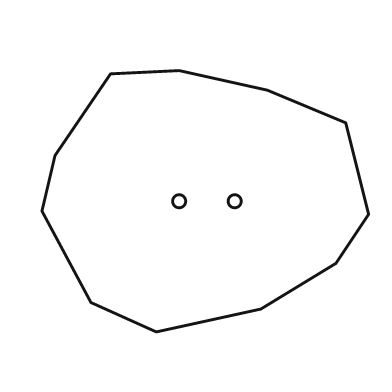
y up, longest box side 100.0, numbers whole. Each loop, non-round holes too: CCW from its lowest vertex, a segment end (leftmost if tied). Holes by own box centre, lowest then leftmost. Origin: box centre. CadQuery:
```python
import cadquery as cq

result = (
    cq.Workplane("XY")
    .moveTo(-15.0, -40.0)
    .lineTo(17.0, -33.0)
    .lineTo(40.0, -19.0)
    .lineTo(50.0, -4.0)
    .lineTo(43.0, 24.0)
    .lineTo(19.0, 34.0)
    .lineTo(-8.0, 40.0)
    .lineTo(-29.0, 39.0)
    .lineTo(-46.0, 14.0)
    .lineTo(-50.0, -3.0)
    .lineTo(-35.0, -31.0)
    .close()
    .moveTo(-8.0, 0.0)
    .circle(2.0)
    .moveTo(9.0, 0.0)
    .circle(2.0)
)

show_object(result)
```